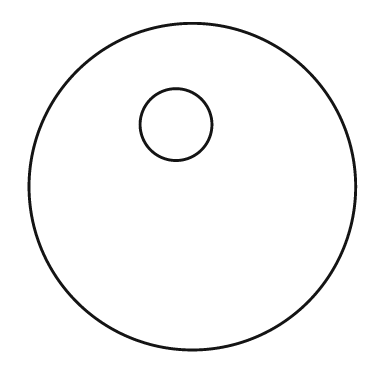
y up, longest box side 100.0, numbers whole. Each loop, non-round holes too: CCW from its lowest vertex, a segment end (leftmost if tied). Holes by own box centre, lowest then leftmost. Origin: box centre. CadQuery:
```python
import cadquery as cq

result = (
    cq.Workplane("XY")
    .moveTo(0.0, 0.0)
    .circle(50.0)
    .moveTo(-5.0, 19.0)
    .circle(11.0)
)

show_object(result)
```